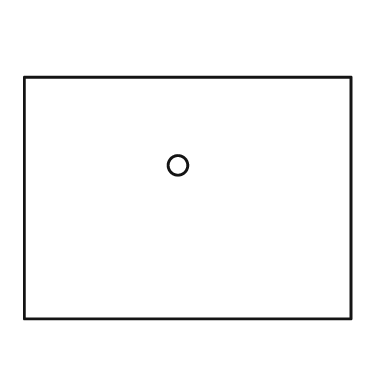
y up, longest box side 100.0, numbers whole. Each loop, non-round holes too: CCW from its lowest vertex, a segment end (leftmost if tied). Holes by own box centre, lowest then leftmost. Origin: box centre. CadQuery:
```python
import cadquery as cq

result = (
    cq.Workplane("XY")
    .moveTo(-50.0, -37.0)
    .lineTo(50.0, -37.0)
    .lineTo(50.0, 37.0)
    .lineTo(-50.0, 37.0)
    .close()
    .moveTo(-3.0, 10.0)
    .circle(3.0)
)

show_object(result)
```